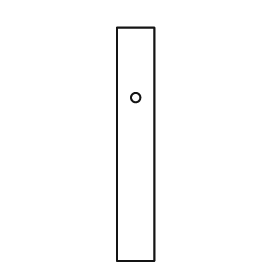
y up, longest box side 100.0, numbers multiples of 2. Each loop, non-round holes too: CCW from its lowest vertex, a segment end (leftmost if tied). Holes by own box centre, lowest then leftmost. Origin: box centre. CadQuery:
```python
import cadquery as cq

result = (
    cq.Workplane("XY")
    .moveTo(-8.0, -50.0)
    .lineTo(8.0, -50.0)
    .lineTo(8.0, 50.0)
    .lineTo(-8.0, 50.0)
    .close()
    .moveTo(0.0, 20.0)
    .circle(2.0)
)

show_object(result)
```